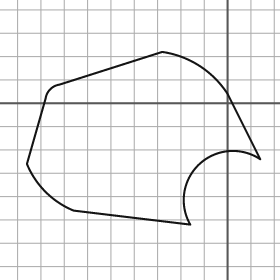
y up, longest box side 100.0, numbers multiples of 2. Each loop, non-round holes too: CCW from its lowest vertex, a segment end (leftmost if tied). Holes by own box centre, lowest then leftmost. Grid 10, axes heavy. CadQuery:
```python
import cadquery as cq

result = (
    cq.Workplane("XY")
    .moveTo(-16.0, -52.0)
    .threePointArc((-12.0, -26.0), (14.0, -24.0))
    .lineTo(0.0, 4.0)
    .threePointArc((-12.0, 16.0), (-28.0, 22.0))
    .lineTo(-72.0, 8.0)
    .threePointArc((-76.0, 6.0), (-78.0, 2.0))
    .lineTo(-86.0, -26.0)
    .threePointArc((-78.0, -38.0), (-66.0, -46.0))
    .close()
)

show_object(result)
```